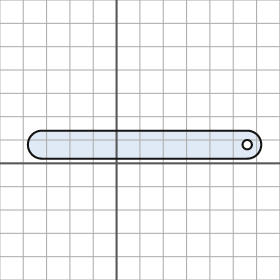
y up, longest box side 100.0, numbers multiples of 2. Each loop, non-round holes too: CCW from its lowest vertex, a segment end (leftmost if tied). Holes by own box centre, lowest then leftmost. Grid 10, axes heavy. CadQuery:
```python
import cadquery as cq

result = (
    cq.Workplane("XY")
    .moveTo(-32.0, 2.0)
    .lineTo(56.0, 2.0)
    .threePointArc((62.0, 8.0), (56.0, 14.0))
    .lineTo(-32.0, 14.0)
    .threePointArc((-38.0, 8.0), (-32.0, 2.0))
    .close()
    .moveTo(56.0, 8.0)
    .circle(2.0)
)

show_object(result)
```